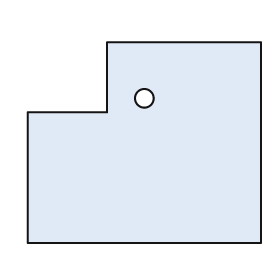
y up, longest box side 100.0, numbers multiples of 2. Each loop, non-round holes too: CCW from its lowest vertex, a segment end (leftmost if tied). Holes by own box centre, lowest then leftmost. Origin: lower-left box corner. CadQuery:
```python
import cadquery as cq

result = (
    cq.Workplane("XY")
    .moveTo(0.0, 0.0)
    .lineTo(100.0, 0.0)
    .lineTo(100.0, 86.0)
    .lineTo(34.0, 86.0)
    .lineTo(34.0, 56.0)
    .lineTo(0.0, 56.0)
    .close()
    .moveTo(50.0, 62.0)
    .circle(4.0)
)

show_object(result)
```